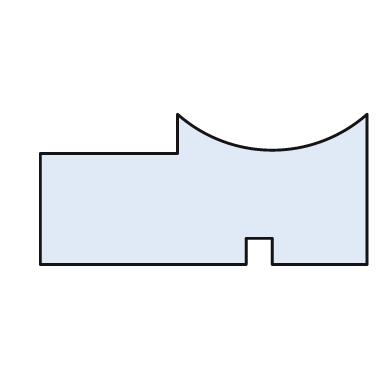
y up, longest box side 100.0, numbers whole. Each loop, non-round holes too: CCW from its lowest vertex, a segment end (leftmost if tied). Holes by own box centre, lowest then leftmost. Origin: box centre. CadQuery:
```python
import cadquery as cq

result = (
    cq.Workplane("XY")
    .moveTo(-50.0, -23.0)
    .lineTo(13.0, -23.0)
    .lineTo(13.0, -15.0)
    .lineTo(21.0, -15.0)
    .lineTo(21.0, -23.0)
    .lineTo(50.0, -23.0)
    .lineTo(50.0, 23.0)
    .threePointArc((21.0, 12.0), (-8.0, 23.0))
    .lineTo(-8.0, 11.0)
    .lineTo(-50.0, 11.0)
    .close()
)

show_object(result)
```